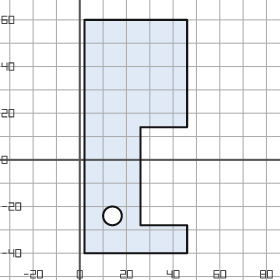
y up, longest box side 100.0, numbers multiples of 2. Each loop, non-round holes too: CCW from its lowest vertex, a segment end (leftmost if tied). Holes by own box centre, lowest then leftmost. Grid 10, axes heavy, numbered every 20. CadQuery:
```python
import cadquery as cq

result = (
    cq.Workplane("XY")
    .moveTo(2.0, -40.0)
    .lineTo(46.0, -40.0)
    .lineTo(46.0, -28.0)
    .lineTo(26.0, -28.0)
    .lineTo(26.0, 14.0)
    .lineTo(46.0, 14.0)
    .lineTo(46.0, 60.0)
    .lineTo(2.0, 60.0)
    .close()
    .moveTo(14.0, -24.0)
    .circle(4.0)
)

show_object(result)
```